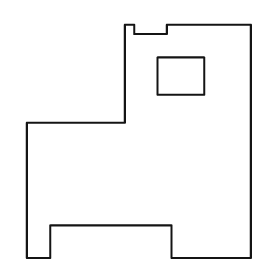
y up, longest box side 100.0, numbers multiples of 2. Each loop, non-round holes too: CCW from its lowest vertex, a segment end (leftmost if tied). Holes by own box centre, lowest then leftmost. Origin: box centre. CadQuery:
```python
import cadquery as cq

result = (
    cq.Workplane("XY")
    .moveTo(-48.0, -50.0)
    .lineTo(-38.0, -50.0)
    .lineTo(-38.0, -36.0)
    .lineTo(14.0, -36.0)
    .lineTo(14.0, -50.0)
    .lineTo(48.0, -50.0)
    .lineTo(48.0, 50.0)
    .lineTo(12.0, 50.0)
    .lineTo(12.0, 46.0)
    .lineTo(-2.0, 46.0)
    .lineTo(-2.0, 50.0)
    .lineTo(-6.0, 50.0)
    .lineTo(-6.0, 8.0)
    .lineTo(-48.0, 8.0)
    .close()
    .moveTo(8.0, 20.0)
    .lineTo(28.0, 20.0)
    .lineTo(28.0, 36.0)
    .lineTo(8.0, 36.0)
    .close()
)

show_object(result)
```